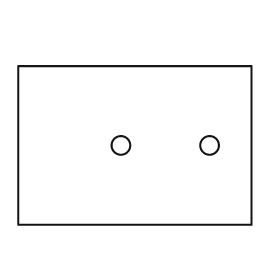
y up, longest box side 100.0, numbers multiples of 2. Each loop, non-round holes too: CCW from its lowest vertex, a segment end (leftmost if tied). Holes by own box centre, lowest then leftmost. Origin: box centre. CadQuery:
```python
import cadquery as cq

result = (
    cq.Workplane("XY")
    .moveTo(-50.0, -34.0)
    .lineTo(50.0, -34.0)
    .lineTo(50.0, 34.0)
    .lineTo(-50.0, 34.0)
    .close()
    .moveTo(-6.0, 0.0)
    .circle(4.0)
    .moveTo(32.0, 0.0)
    .circle(4.0)
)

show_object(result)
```